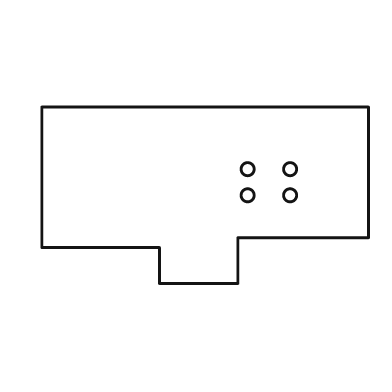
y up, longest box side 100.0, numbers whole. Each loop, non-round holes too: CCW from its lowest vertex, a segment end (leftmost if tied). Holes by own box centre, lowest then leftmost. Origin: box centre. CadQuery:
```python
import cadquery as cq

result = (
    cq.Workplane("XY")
    .moveTo(-14.0, -27.0)
    .lineTo(10.0, -27.0)
    .lineTo(10.0, -13.0)
    .lineTo(50.0, -13.0)
    .lineTo(50.0, 27.0)
    .lineTo(-50.0, 27.0)
    .lineTo(-50.0, -16.0)
    .lineTo(-14.0, -16.0)
    .close()
    .moveTo(13.0, 0.0)
    .circle(2.0)
    .moveTo(26.0, 0.0)
    .circle(2.0)
    .moveTo(13.0, 8.0)
    .circle(2.0)
    .moveTo(26.0, 8.0)
    .circle(2.0)
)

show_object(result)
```